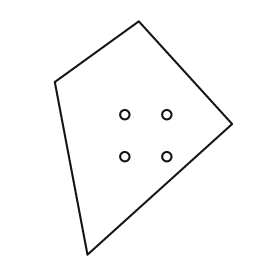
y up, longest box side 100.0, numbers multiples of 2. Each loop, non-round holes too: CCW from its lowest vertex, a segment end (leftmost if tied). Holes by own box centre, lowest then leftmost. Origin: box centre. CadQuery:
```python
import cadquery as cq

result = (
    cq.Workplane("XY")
    .moveTo(-24.0, -50.0)
    .lineTo(38.0, 6.0)
    .lineTo(-2.0, 50.0)
    .lineTo(-38.0, 24.0)
    .close()
    .moveTo(-8.0, -8.0)
    .circle(2.0)
    .moveTo(10.0, -8.0)
    .circle(2.0)
    .moveTo(-8.0, 10.0)
    .circle(2.0)
    .moveTo(10.0, 10.0)
    .circle(2.0)
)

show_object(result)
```